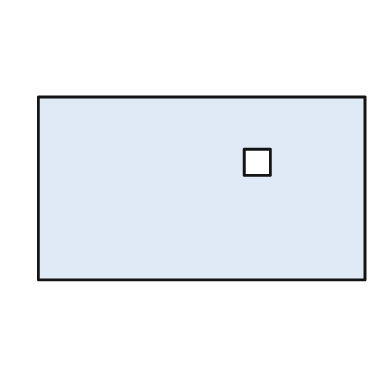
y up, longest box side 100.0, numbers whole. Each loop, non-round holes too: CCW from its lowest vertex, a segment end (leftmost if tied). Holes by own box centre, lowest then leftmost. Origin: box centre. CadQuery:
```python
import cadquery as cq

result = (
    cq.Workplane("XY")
    .moveTo(-50.0, -28.0)
    .lineTo(50.0, -28.0)
    .lineTo(50.0, 28.0)
    .lineTo(-50.0, 28.0)
    .close()
    .moveTo(13.0, 4.0)
    .lineTo(21.0, 4.0)
    .lineTo(21.0, 12.0)
    .lineTo(13.0, 12.0)
    .close()
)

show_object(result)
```